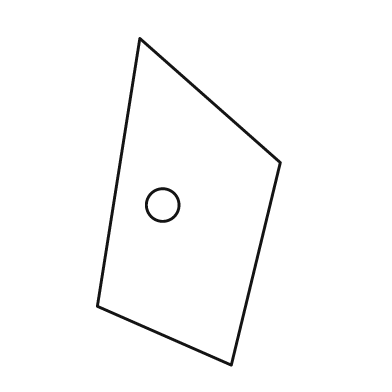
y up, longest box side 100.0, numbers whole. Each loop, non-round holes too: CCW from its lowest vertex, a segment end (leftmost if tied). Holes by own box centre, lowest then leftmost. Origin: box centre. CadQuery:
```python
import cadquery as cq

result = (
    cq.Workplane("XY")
    .moveTo(13.0, -50.0)
    .lineTo(28.0, 12.0)
    .lineTo(-15.0, 50.0)
    .lineTo(-28.0, -32.0)
    .close()
    .moveTo(-8.0, -1.0)
    .circle(5.0)
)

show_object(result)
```